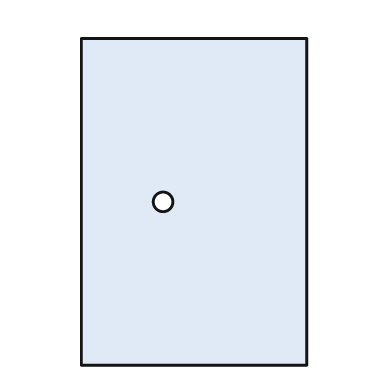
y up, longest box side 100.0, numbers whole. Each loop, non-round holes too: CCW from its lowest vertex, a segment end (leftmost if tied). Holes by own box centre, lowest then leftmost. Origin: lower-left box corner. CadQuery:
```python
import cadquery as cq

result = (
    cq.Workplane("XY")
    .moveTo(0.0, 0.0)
    .lineTo(69.0, 0.0)
    .lineTo(69.0, 100.0)
    .lineTo(0.0, 100.0)
    .close()
    .moveTo(25.0, 50.0)
    .circle(3.0)
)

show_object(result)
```